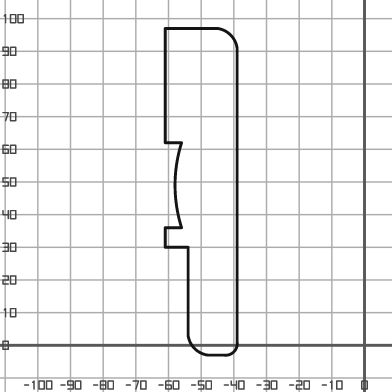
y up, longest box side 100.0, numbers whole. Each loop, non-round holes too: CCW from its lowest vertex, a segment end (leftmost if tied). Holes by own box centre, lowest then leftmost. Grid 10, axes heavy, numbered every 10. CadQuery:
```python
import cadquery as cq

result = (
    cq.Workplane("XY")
    .moveTo(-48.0, -3.0)
    .lineTo(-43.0, -3.0)
    .threePointArc((-40.0, -2.0), (-39.0, 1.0))
    .lineTo(-39.0, 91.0)
    .threePointArc((-41.0, 95.0), (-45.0, 97.0))
    .lineTo(-61.0, 97.0)
    .lineTo(-61.0, 62.0)
    .lineTo(-56.0, 62.0)
    .threePointArc((-58.0, 49.0), (-56.0, 36.0))
    .lineTo(-61.0, 36.0)
    .lineTo(-61.0, 30.0)
    .lineTo(-54.0, 30.0)
    .lineTo(-54.0, 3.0)
    .threePointArc((-52.0, -1.0), (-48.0, -3.0))
    .close()
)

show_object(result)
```